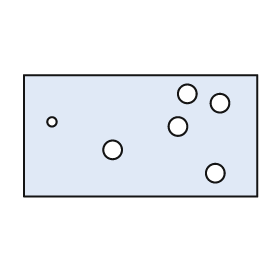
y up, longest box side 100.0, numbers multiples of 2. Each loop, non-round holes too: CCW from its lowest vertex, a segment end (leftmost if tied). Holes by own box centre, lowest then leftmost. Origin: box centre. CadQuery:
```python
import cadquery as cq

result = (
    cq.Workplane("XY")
    .moveTo(-50.0, -26.0)
    .lineTo(50.0, -26.0)
    .lineTo(50.0, 26.0)
    .lineTo(-50.0, 26.0)
    .close()
    .moveTo(32.0, -16.0)
    .circle(4.0)
    .moveTo(-12.0, -6.0)
    .circle(4.0)
    .moveTo(16.0, 4.0)
    .circle(4.0)
    .moveTo(-38.0, 6.0)
    .circle(2.0)
    .moveTo(34.0, 14.0)
    .circle(4.0)
    .moveTo(20.0, 18.0)
    .circle(4.0)
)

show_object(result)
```